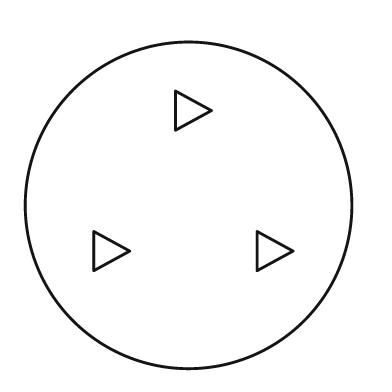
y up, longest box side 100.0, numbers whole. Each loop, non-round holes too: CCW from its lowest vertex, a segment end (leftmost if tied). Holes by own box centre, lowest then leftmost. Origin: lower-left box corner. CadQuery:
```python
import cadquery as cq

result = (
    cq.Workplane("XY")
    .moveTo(50.0, 50.0)
    .circle(50.0)
    .moveTo(21.0, 30.0)
    .lineTo(32.0, 36.0)
    .lineTo(21.0, 42.0)
    .close()
    .moveTo(71.0, 30.0)
    .lineTo(82.0, 36.0)
    .lineTo(71.0, 42.0)
    .close()
    .moveTo(46.0, 73.0)
    .lineTo(57.0, 79.0)
    .lineTo(46.0, 85.0)
    .close()
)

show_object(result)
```